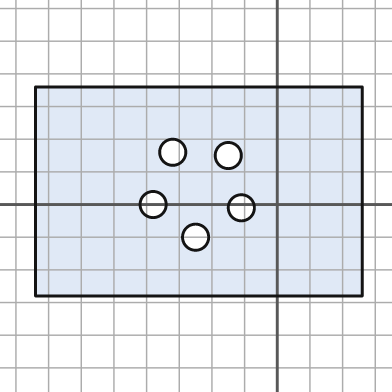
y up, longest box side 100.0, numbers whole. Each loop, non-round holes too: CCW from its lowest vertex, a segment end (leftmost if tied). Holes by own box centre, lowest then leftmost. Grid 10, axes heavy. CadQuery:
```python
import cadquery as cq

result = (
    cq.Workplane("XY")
    .moveTo(-74.0, -28.0)
    .lineTo(26.0, -28.0)
    .lineTo(26.0, 36.0)
    .lineTo(-74.0, 36.0)
    .close()
    .moveTo(-25.0, -10.0)
    .circle(4.0)
    .moveTo(-11.0, -1.0)
    .circle(4.0)
    .moveTo(-38.0, 0.0)
    .circle(4.0)
    .moveTo(-15.0, 15.0)
    .circle(4.0)
    .moveTo(-32.0, 16.0)
    .circle(4.0)
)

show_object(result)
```